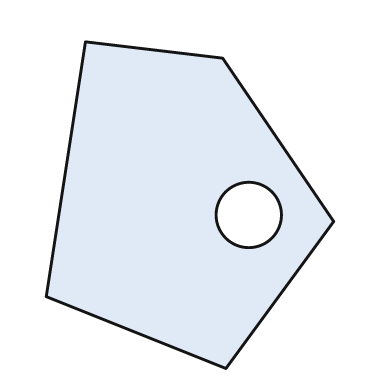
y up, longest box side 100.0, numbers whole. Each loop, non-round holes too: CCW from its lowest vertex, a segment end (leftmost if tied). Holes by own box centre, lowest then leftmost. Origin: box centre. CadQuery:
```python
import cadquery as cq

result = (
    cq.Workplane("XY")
    .moveTo(11.0, -50.0)
    .lineTo(44.0, -5.0)
    .lineTo(10.0, 45.0)
    .lineTo(-32.0, 50.0)
    .lineTo(-44.0, -28.0)
    .close()
    .moveTo(18.0, -3.0)
    .circle(10.0)
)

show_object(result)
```